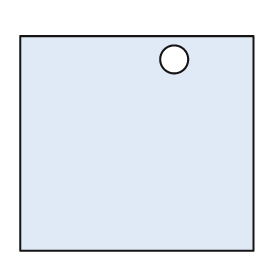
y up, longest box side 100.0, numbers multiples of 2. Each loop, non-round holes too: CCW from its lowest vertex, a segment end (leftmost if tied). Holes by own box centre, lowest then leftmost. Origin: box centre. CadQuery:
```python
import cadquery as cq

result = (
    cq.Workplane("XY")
    .moveTo(-50.0, -46.0)
    .lineTo(50.0, -46.0)
    .lineTo(50.0, 46.0)
    .lineTo(-50.0, 46.0)
    .close()
    .moveTo(16.0, 36.0)
    .circle(6.0)
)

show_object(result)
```